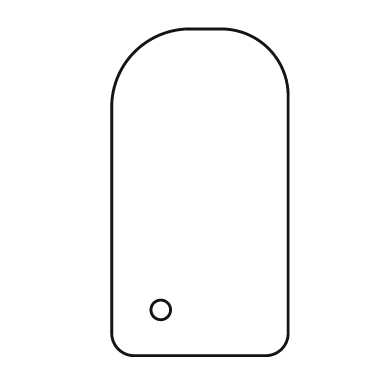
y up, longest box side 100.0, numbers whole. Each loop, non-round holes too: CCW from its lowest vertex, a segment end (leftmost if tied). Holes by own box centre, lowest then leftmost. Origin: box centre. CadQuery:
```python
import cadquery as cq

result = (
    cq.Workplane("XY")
    .moveTo(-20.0, -50.0)
    .lineTo(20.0, -50.0)
    .threePointArc((25.0, -48.0), (27.0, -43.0))
    .lineTo(27.0, 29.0)
    .threePointArc((21.0, 44.0), (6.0, 50.0))
    .lineTo(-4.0, 50.0)
    .threePointArc((-20.0, 43.0), (-27.0, 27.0))
    .lineTo(-27.0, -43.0)
    .threePointArc((-25.0, -48.0), (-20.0, -50.0))
    .close()
    .moveTo(-12.0, -36.0)
    .circle(3.0)
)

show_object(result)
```